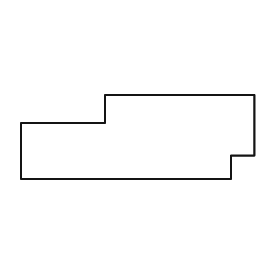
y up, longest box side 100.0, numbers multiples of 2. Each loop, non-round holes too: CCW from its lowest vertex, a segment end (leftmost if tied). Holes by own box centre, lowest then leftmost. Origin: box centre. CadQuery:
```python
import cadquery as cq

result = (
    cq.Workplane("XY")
    .moveTo(-50.0, -18.0)
    .lineTo(40.0, -18.0)
    .lineTo(40.0, -8.0)
    .lineTo(50.0, -8.0)
    .lineTo(50.0, 18.0)
    .lineTo(-14.0, 18.0)
    .lineTo(-14.0, 6.0)
    .lineTo(-50.0, 6.0)
    .close()
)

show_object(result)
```